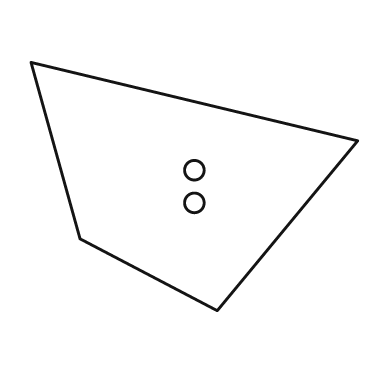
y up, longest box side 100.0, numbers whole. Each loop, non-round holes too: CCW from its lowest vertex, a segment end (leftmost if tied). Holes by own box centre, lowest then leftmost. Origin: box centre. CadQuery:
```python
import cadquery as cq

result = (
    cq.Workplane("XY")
    .moveTo(7.0, -38.0)
    .lineTo(50.0, 14.0)
    .lineTo(-50.0, 38.0)
    .lineTo(-35.0, -16.0)
    .close()
    .moveTo(0.0, -5.0)
    .circle(3.0)
    .moveTo(0.0, 5.0)
    .circle(3.0)
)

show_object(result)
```